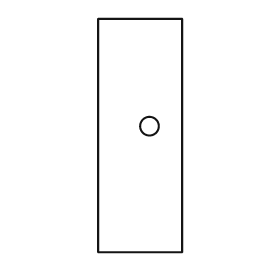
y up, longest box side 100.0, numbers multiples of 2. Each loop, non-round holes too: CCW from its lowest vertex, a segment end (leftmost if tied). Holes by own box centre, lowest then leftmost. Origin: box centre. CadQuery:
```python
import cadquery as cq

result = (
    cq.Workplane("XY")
    .moveTo(-18.0, -50.0)
    .lineTo(18.0, -50.0)
    .lineTo(18.0, 50.0)
    .lineTo(-18.0, 50.0)
    .close()
    .moveTo(4.0, 4.0)
    .circle(4.0)
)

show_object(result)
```